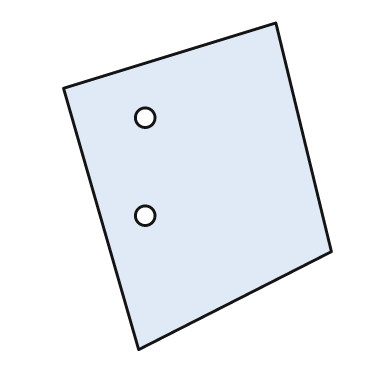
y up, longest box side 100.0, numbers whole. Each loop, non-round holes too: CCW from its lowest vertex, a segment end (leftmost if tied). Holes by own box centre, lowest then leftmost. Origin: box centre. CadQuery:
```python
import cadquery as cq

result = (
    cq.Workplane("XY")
    .moveTo(-18.0, -50.0)
    .lineTo(41.0, -20.0)
    .lineTo(24.0, 50.0)
    .lineTo(-41.0, 30.0)
    .close()
    .moveTo(-16.0, -9.0)
    .circle(3.0)
    .moveTo(-16.0, 21.0)
    .circle(3.0)
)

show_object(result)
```